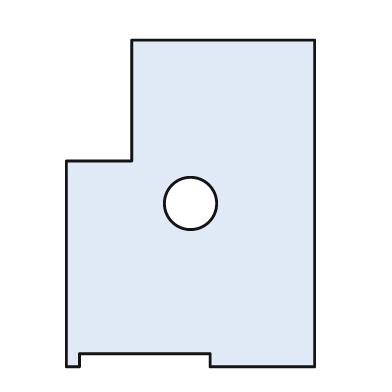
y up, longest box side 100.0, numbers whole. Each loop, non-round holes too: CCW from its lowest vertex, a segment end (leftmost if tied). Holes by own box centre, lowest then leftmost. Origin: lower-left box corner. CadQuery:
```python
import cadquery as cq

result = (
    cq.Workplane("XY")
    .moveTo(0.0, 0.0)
    .lineTo(4.0, 0.0)
    .lineTo(4.0, 4.0)
    .lineTo(44.0, 4.0)
    .lineTo(44.0, 0.0)
    .lineTo(76.0, 0.0)
    .lineTo(76.0, 100.0)
    .lineTo(20.0, 100.0)
    .lineTo(20.0, 63.0)
    .lineTo(0.0, 63.0)
    .close()
    .moveTo(38.0, 50.0)
    .circle(8.0)
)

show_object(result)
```